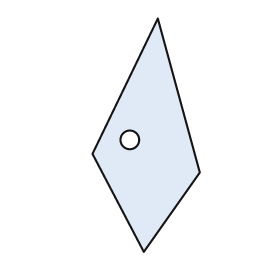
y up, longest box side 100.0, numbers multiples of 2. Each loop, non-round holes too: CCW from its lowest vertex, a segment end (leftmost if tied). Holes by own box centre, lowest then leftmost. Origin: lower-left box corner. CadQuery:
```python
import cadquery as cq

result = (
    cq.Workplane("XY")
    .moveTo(22.0, 0.0)
    .lineTo(46.0, 34.0)
    .lineTo(28.0, 100.0)
    .lineTo(0.0, 42.0)
    .close()
    .moveTo(16.0, 48.0)
    .circle(4.0)
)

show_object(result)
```